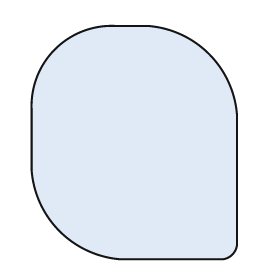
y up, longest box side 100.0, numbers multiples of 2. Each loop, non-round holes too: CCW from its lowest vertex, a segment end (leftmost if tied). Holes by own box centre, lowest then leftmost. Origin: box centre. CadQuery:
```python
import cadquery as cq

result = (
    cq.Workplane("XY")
    .moveTo(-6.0, -50.0)
    .lineTo(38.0, -50.0)
    .threePointArc((42.0, -48.0), (44.0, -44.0))
    .lineTo(44.0, 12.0)
    .threePointArc((32.0, 38.0), (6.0, 50.0))
    .lineTo(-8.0, 50.0)
    .threePointArc((-34.0, 40.0), (-44.0, 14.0))
    .lineTo(-44.0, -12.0)
    .threePointArc((-32.0, -38.0), (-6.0, -50.0))
    .close()
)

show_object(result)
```